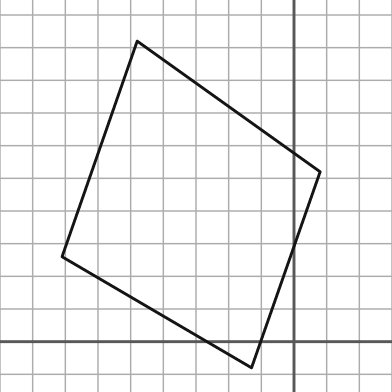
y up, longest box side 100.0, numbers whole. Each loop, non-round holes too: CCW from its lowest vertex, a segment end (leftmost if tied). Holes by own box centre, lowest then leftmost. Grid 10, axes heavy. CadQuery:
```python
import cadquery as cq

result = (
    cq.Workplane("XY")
    .moveTo(-13.0, -8.0)
    .lineTo(8.0, 52.0)
    .lineTo(-48.0, 92.0)
    .lineTo(-71.0, 26.0)
    .close()
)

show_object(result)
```